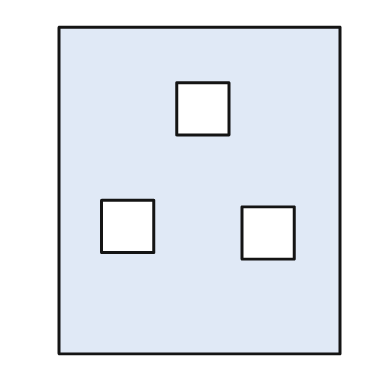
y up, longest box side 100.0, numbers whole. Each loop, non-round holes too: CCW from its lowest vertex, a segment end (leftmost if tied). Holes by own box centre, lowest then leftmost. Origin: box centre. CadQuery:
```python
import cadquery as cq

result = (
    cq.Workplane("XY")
    .moveTo(-43.0, -50.0)
    .lineTo(43.0, -50.0)
    .lineTo(43.0, 50.0)
    .lineTo(-43.0, 50.0)
    .close()
    .moveTo(13.0, -21.0)
    .lineTo(29.0, -21.0)
    .lineTo(29.0, -5.0)
    .lineTo(13.0, -5.0)
    .close()
    .moveTo(-30.0, -19.0)
    .lineTo(-14.0, -19.0)
    .lineTo(-14.0, -3.0)
    .lineTo(-30.0, -3.0)
    .close()
    .moveTo(-7.0, 17.0)
    .lineTo(9.0, 17.0)
    .lineTo(9.0, 33.0)
    .lineTo(-7.0, 33.0)
    .close()
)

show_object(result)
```